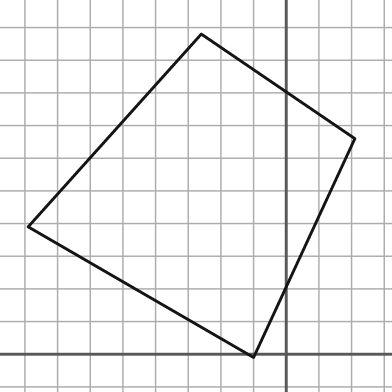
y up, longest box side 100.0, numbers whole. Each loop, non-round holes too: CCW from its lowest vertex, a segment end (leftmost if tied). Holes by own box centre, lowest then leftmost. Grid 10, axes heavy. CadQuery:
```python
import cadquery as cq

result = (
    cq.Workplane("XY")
    .moveTo(-10.0, -1.0)
    .lineTo(21.0, 66.0)
    .lineTo(-26.0, 98.0)
    .lineTo(-79.0, 39.0)
    .close()
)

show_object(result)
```